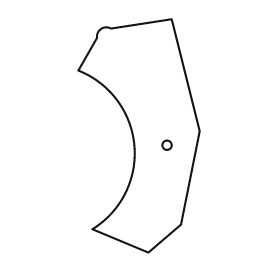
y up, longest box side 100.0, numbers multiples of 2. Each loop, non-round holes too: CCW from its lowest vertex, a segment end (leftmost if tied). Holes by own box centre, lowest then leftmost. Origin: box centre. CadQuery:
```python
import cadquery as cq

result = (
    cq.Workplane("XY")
    .moveTo(4.0, -50.0)
    .lineTo(18.0, -38.0)
    .lineTo(26.0, 2.0)
    .lineTo(14.0, 50.0)
    .lineTo(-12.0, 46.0)
    .threePointArc((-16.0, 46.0), (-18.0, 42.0))
    .lineTo(-26.0, 28.0)
    .threePointArc((-2.0, -4.0), (-20.0, -40.0))
    .close()
    .moveTo(12.0, -4.0)
    .circle(2.0)
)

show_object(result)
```